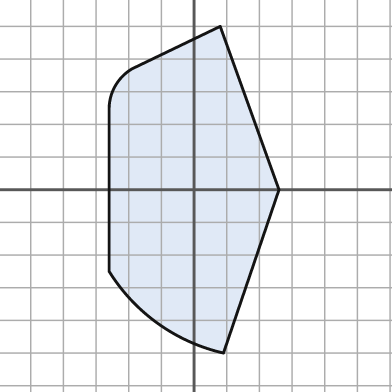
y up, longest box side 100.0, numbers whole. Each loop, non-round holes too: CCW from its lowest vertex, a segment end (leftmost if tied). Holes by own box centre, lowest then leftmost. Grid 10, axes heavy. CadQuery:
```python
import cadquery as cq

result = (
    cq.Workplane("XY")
    .moveTo(9.0, -50.0)
    .lineTo(26.0, 0.0)
    .lineTo(8.0, 50.0)
    .lineTo(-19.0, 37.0)
    .threePointArc((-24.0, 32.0), (-26.0, 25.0))
    .lineTo(-26.0, -25.0)
    .threePointArc((-11.0, -41.0), (9.0, -50.0))
    .close()
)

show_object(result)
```